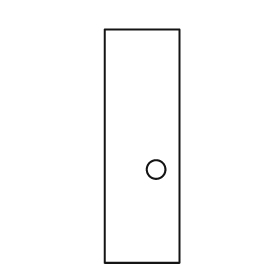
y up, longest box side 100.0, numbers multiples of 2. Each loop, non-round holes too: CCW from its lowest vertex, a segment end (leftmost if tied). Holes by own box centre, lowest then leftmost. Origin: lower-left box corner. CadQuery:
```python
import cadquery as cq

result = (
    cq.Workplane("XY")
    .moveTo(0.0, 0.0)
    .lineTo(32.0, 0.0)
    .lineTo(32.0, 100.0)
    .lineTo(0.0, 100.0)
    .close()
    .moveTo(22.0, 40.0)
    .circle(4.0)
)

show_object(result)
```